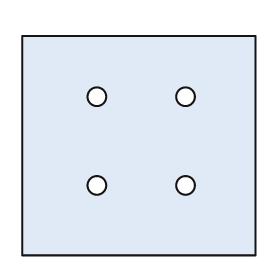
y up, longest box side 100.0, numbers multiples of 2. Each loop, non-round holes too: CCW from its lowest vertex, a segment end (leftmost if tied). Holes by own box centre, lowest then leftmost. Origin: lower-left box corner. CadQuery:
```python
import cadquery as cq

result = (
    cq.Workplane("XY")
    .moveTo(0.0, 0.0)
    .lineTo(100.0, 0.0)
    .lineTo(100.0, 94.0)
    .lineTo(0.0, 94.0)
    .close()
    .moveTo(32.0, 30.0)
    .circle(4.0)
    .moveTo(70.0, 30.0)
    .circle(4.0)
    .moveTo(32.0, 68.0)
    .circle(4.0)
    .moveTo(70.0, 68.0)
    .circle(4.0)
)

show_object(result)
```